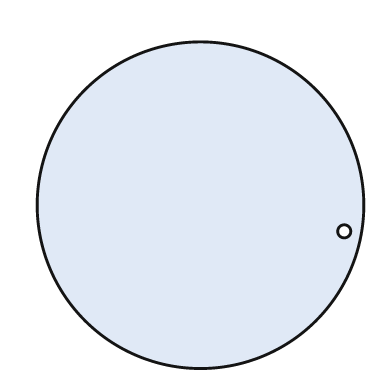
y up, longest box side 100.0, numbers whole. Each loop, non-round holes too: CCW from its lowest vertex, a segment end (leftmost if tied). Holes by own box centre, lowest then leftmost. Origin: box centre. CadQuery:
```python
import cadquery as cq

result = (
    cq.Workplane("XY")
    .moveTo(0.0, 0.0)
    .circle(50.0)
    .moveTo(44.0, -8.0)
    .circle(2.0)
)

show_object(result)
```